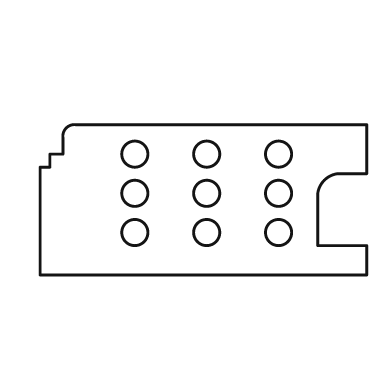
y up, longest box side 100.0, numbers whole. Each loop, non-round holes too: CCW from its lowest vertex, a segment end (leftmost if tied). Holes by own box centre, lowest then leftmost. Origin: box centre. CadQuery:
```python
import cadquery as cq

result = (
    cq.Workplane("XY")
    .moveTo(-50.0, -23.0)
    .lineTo(50.0, -23.0)
    .lineTo(50.0, -14.0)
    .lineTo(35.0, -14.0)
    .lineTo(35.0, 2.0)
    .threePointArc((37.0, 6.0), (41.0, 8.0))
    .lineTo(50.0, 8.0)
    .lineTo(50.0, 23.0)
    .lineTo(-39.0, 23.0)
    .threePointArc((-42.0, 22.0), (-43.0, 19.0))
    .lineTo(-43.0, 14.0)
    .lineTo(-47.0, 14.0)
    .lineTo(-47.0, 10.0)
    .lineTo(-50.0, 10.0)
    .close()
    .moveTo(-21.0, -10.0)
    .circle(4.0)
    .moveTo(1.0, -10.0)
    .circle(4.0)
    .moveTo(23.0, -10.0)
    .circle(4.0)
    .moveTo(-21.0, 2.0)
    .circle(4.0)
    .moveTo(1.0, 2.0)
    .circle(4.0)
    .moveTo(23.0, 2.0)
    .circle(4.0)
    .moveTo(-21.0, 14.0)
    .circle(4.0)
    .moveTo(1.0, 14.0)
    .circle(4.0)
    .moveTo(23.0, 14.0)
    .circle(4.0)
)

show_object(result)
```